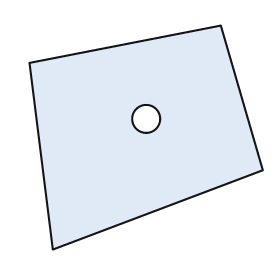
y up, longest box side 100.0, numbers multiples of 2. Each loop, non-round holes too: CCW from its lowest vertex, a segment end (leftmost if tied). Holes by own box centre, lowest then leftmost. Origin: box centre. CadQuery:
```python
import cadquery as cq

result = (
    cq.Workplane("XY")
    .moveTo(-40.0, -48.0)
    .lineTo(50.0, -14.0)
    .lineTo(32.0, 48.0)
    .lineTo(-50.0, 32.0)
    .close()
    .moveTo(0.0, 8.0)
    .circle(6.0)
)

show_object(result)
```